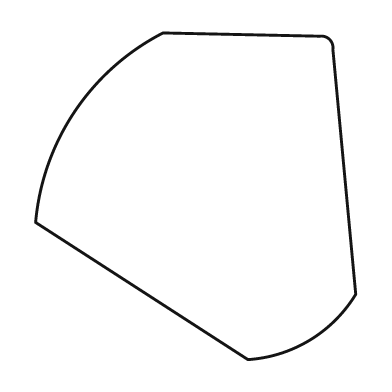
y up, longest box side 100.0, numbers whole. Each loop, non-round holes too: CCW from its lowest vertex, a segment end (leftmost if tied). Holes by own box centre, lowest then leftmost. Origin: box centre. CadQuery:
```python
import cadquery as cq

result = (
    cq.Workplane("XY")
    .moveTo(16.0, -50.0)
    .threePointArc((35.0, -44.0), (49.0, -30.0))
    .lineTo(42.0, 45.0)
    .threePointArc((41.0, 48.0), (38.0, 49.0))
    .lineTo(-10.0, 50.0)
    .threePointArc((-37.0, 26.0), (-49.0, -8.0))
    .close()
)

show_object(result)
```